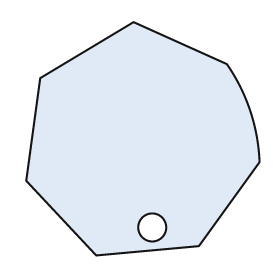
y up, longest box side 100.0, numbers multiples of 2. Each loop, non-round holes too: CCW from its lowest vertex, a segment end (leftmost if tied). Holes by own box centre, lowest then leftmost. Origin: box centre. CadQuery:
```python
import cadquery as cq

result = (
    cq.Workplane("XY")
    .moveTo(-20.0, -50.0)
    .lineTo(24.0, -46.0)
    .lineTo(50.0, -10.0)
    .threePointArc((46.0, 12.0), (36.0, 32.0))
    .lineTo(-4.0, 50.0)
    .lineTo(-44.0, 26.0)
    .lineTo(-50.0, -18.0)
    .close()
    .moveTo(4.0, -38.0)
    .circle(6.0)
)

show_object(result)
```